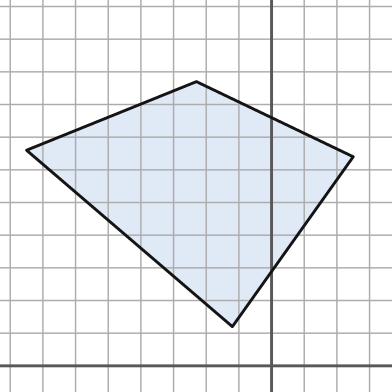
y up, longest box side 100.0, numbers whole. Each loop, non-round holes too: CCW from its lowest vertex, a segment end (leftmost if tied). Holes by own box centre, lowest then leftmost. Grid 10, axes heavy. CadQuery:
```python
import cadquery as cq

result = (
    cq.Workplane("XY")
    .moveTo(-12.0, 12.0)
    .lineTo(25.0, 64.0)
    .lineTo(-23.0, 87.0)
    .lineTo(-75.0, 66.0)
    .close()
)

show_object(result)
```